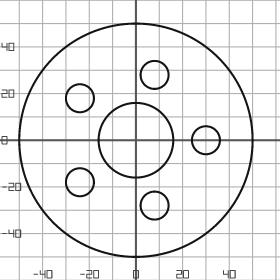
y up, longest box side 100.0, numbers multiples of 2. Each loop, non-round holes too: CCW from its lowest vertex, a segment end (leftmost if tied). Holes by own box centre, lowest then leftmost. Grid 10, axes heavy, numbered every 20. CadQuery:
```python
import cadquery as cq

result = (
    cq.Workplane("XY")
    .moveTo(0.0, 0.0)
    .circle(50.0)
    .moveTo(8.0, -28.0)
    .circle(6.0)
    .moveTo(-24.0, -18.0)
    .circle(6.0)
    .moveTo(0.0, 0.0)
    .circle(16.0)
    .moveTo(30.0, 0.0)
    .circle(6.0)
    .moveTo(-24.0, 18.0)
    .circle(6.0)
    .moveTo(8.0, 28.0)
    .circle(6.0)
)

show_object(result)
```